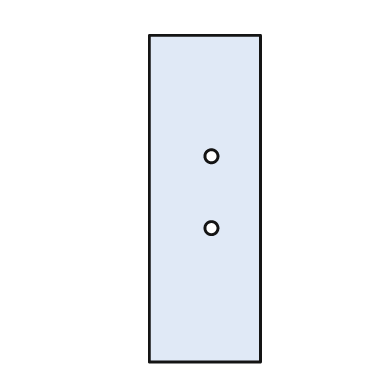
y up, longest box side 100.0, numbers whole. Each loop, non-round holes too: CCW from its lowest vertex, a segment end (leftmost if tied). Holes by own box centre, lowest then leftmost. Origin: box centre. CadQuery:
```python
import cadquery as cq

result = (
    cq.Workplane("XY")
    .moveTo(-17.0, -50.0)
    .lineTo(17.0, -50.0)
    .lineTo(17.0, 50.0)
    .lineTo(-17.0, 50.0)
    .close()
    .moveTo(2.0, -9.0)
    .circle(2.0)
    .moveTo(2.0, 13.0)
    .circle(2.0)
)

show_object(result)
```